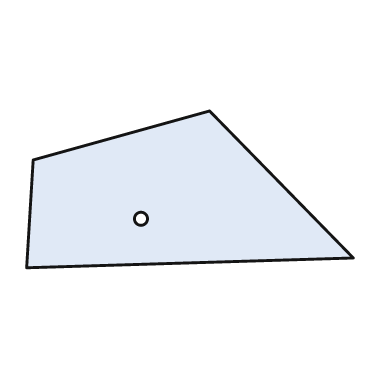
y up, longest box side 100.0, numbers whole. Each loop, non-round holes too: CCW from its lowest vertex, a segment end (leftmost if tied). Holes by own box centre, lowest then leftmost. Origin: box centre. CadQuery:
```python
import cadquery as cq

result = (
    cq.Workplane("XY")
    .moveTo(-50.0, -24.0)
    .lineTo(50.0, -21.0)
    .lineTo(6.0, 24.0)
    .lineTo(-48.0, 9.0)
    .close()
    .moveTo(-15.0, -9.0)
    .circle(2.0)
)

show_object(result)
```